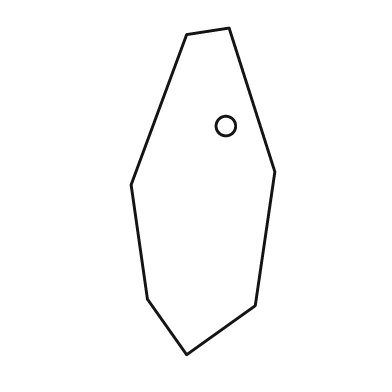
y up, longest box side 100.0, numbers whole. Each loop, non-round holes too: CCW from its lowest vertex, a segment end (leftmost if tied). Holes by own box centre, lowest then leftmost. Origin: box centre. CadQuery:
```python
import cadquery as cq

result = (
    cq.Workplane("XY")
    .moveTo(-5.0, -50.0)
    .lineTo(16.0, -35.0)
    .lineTo(22.0, 6.0)
    .lineTo(8.0, 50.0)
    .lineTo(-5.0, 48.0)
    .lineTo(-22.0, 2.0)
    .lineTo(-17.0, -33.0)
    .close()
    .moveTo(7.0, 20.0)
    .circle(3.0)
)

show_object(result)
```